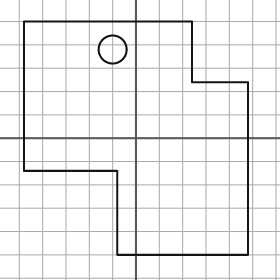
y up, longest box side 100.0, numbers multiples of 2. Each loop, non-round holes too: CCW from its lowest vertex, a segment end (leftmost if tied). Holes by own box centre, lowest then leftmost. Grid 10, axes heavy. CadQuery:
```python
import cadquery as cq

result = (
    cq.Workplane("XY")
    .moveTo(-8.0, -50.0)
    .lineTo(48.0, -50.0)
    .lineTo(48.0, 24.0)
    .lineTo(24.0, 24.0)
    .lineTo(24.0, 50.0)
    .lineTo(-48.0, 50.0)
    .lineTo(-48.0, -14.0)
    .lineTo(-8.0, -14.0)
    .close()
    .moveTo(-10.0, 38.0)
    .circle(6.0)
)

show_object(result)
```